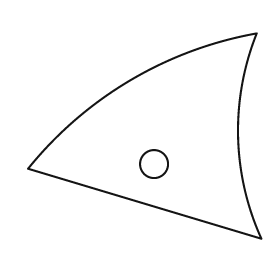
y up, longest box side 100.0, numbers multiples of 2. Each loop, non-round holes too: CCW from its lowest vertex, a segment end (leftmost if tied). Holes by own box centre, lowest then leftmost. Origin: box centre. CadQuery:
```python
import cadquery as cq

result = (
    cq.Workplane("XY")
    .moveTo(50.0, -44.0)
    .threePointArc((40.0, 0.0), (48.0, 44.0))
    .threePointArc((-6.0, 24.0), (-50.0, -14.0))
    .close()
    .moveTo(4.0, -12.0)
    .circle(6.0)
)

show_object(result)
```